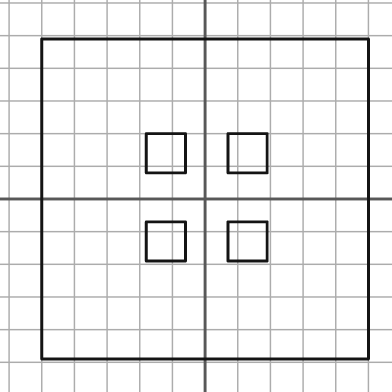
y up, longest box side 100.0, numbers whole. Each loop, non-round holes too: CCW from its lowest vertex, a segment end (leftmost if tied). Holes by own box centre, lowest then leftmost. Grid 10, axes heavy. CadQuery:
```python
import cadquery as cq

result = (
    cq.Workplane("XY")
    .moveTo(-50.0, -49.0)
    .lineTo(50.0, -49.0)
    .lineTo(50.0, 49.0)
    .lineTo(-50.0, 49.0)
    .close()
    .moveTo(-18.0, -19.0)
    .lineTo(-6.0, -19.0)
    .lineTo(-6.0, -7.0)
    .lineTo(-18.0, -7.0)
    .close()
    .moveTo(7.0, -19.0)
    .lineTo(19.0, -19.0)
    .lineTo(19.0, -7.0)
    .lineTo(7.0, -7.0)
    .close()
    .moveTo(-18.0, 8.0)
    .lineTo(-6.0, 8.0)
    .lineTo(-6.0, 20.0)
    .lineTo(-18.0, 20.0)
    .close()
    .moveTo(7.0, 8.0)
    .lineTo(19.0, 8.0)
    .lineTo(19.0, 20.0)
    .lineTo(7.0, 20.0)
    .close()
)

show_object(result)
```